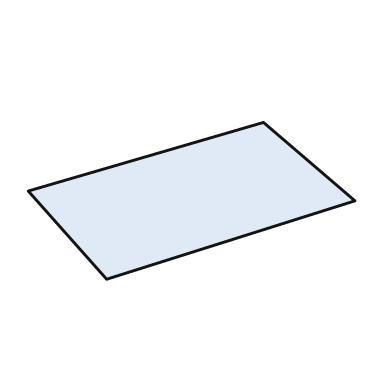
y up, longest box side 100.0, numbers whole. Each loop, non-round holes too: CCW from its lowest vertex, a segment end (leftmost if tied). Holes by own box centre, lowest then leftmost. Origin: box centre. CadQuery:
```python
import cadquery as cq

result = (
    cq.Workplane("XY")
    .moveTo(-26.0, -24.0)
    .lineTo(50.0, 0.0)
    .lineTo(22.0, 24.0)
    .lineTo(-50.0, 3.0)
    .close()
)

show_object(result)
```